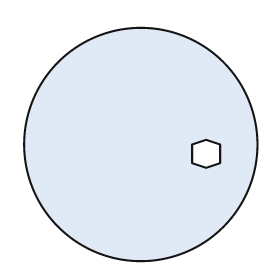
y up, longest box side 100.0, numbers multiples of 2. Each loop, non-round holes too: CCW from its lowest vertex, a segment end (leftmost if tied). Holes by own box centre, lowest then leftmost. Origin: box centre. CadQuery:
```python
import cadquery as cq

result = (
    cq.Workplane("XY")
    .moveTo(0.0, 0.0)
    .circle(50.0)
    .moveTo(28.0, -10.0)
    .lineTo(34.0, -8.0)
    .lineTo(34.0, 0.0)
    .lineTo(28.0, 2.0)
    .lineTo(22.0, 0.0)
    .lineTo(22.0, -8.0)
    .close()
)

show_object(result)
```